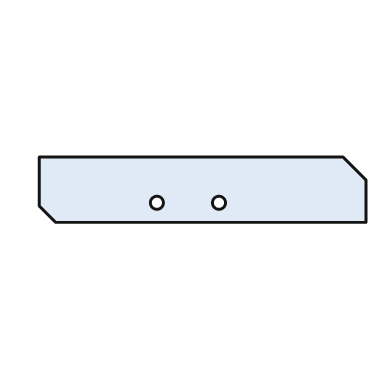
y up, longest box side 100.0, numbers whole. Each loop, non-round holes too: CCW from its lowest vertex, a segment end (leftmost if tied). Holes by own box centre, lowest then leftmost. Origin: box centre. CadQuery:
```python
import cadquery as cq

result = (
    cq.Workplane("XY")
    .moveTo(-45.0, -10.0)
    .lineTo(50.0, -10.0)
    .lineTo(50.0, 3.0)
    .lineTo(43.0, 10.0)
    .lineTo(-50.0, 10.0)
    .lineTo(-50.0, -5.0)
    .close()
    .moveTo(-14.0, -4.0)
    .circle(2.0)
    .moveTo(5.0, -4.0)
    .circle(2.0)
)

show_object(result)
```